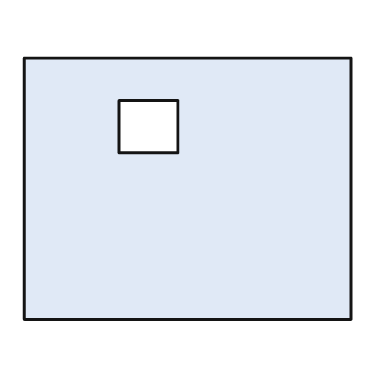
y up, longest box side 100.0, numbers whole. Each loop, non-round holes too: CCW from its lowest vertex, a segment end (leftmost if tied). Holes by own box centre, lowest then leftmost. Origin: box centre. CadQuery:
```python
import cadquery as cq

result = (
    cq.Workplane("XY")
    .moveTo(-50.0, -40.0)
    .lineTo(50.0, -40.0)
    .lineTo(50.0, 40.0)
    .lineTo(-50.0, 40.0)
    .close()
    .moveTo(-21.0, 11.0)
    .lineTo(-3.0, 11.0)
    .lineTo(-3.0, 27.0)
    .lineTo(-21.0, 27.0)
    .close()
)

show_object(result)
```